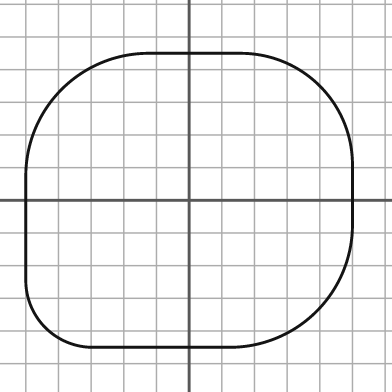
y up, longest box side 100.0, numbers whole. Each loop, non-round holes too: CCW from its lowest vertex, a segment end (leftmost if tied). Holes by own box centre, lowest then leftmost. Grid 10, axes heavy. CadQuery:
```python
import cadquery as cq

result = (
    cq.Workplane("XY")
    .moveTo(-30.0, -45.0)
    .lineTo(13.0, -45.0)
    .threePointArc((39.0, -34.0), (50.0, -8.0))
    .lineTo(50.0, 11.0)
    .threePointArc((40.0, 35.0), (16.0, 45.0))
    .lineTo(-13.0, 45.0)
    .threePointArc((-39.0, 34.0), (-50.0, 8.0))
    .lineTo(-50.0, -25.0)
    .threePointArc((-44.0, -39.0), (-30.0, -45.0))
    .close()
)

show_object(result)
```